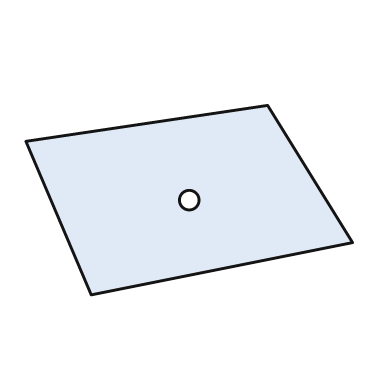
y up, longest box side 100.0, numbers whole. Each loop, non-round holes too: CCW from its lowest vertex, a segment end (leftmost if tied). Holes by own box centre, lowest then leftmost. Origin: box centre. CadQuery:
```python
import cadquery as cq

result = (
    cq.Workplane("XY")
    .moveTo(-30.0, -29.0)
    .lineTo(50.0, -13.0)
    .lineTo(24.0, 29.0)
    .lineTo(-50.0, 18.0)
    .close()
    .moveTo(0.0, 0.0)
    .circle(3.0)
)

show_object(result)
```